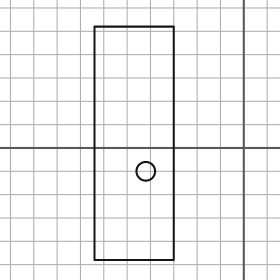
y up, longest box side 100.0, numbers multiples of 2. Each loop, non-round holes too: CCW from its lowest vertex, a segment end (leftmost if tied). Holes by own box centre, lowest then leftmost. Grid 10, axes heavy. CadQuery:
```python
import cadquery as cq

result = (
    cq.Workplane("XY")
    .moveTo(-64.0, -48.0)
    .lineTo(-30.0, -48.0)
    .lineTo(-30.0, 52.0)
    .lineTo(-64.0, 52.0)
    .close()
    .moveTo(-42.0, -10.0)
    .circle(4.0)
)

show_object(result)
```